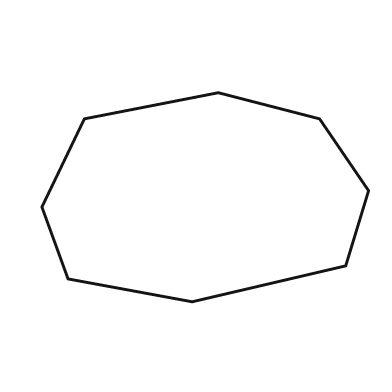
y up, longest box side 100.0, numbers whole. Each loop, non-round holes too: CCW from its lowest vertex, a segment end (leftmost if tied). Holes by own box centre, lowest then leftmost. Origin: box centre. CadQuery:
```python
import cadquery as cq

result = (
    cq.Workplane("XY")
    .moveTo(-4.0, -32.0)
    .lineTo(43.0, -21.0)
    .lineTo(50.0, 2.0)
    .lineTo(35.0, 24.0)
    .lineTo(4.0, 32.0)
    .lineTo(-37.0, 24.0)
    .lineTo(-50.0, -3.0)
    .lineTo(-42.0, -25.0)
    .close()
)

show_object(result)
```